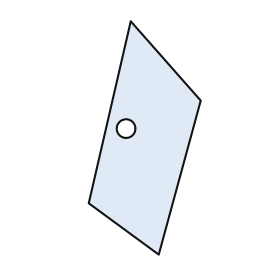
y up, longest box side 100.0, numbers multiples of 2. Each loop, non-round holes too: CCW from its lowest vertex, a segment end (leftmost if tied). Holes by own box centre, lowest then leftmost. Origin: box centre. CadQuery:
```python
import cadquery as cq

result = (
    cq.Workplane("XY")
    .moveTo(6.0, -50.0)
    .lineTo(24.0, 16.0)
    .lineTo(-6.0, 50.0)
    .lineTo(-24.0, -28.0)
    .close()
    .moveTo(-8.0, 4.0)
    .circle(4.0)
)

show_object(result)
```